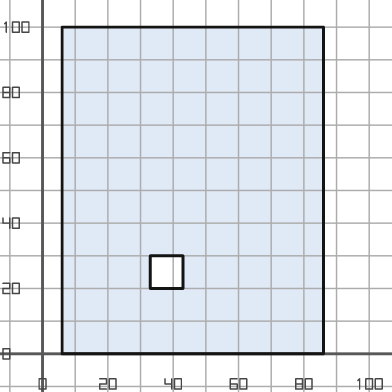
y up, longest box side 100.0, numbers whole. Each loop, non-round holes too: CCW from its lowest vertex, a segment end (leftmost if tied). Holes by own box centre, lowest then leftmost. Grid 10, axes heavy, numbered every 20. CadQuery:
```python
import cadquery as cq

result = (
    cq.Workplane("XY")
    .moveTo(6.0, 0.0)
    .lineTo(86.0, 0.0)
    .lineTo(86.0, 100.0)
    .lineTo(6.0, 100.0)
    .close()
    .moveTo(33.0, 20.0)
    .lineTo(43.0, 20.0)
    .lineTo(43.0, 30.0)
    .lineTo(33.0, 30.0)
    .close()
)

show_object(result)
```